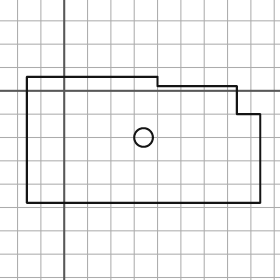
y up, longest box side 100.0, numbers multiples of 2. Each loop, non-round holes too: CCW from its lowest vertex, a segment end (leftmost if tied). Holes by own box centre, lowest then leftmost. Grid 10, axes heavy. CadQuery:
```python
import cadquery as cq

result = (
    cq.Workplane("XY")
    .moveTo(-16.0, -48.0)
    .lineTo(84.0, -48.0)
    .lineTo(84.0, -10.0)
    .lineTo(74.0, -10.0)
    .lineTo(74.0, 2.0)
    .lineTo(40.0, 2.0)
    .lineTo(40.0, 6.0)
    .lineTo(-16.0, 6.0)
    .close()
    .moveTo(34.0, -20.0)
    .circle(4.0)
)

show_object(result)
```